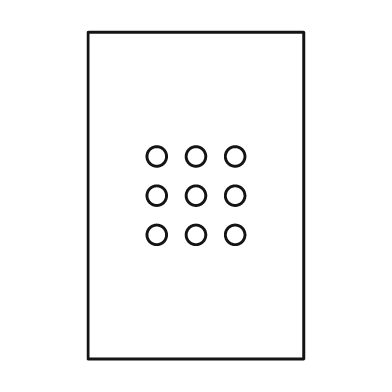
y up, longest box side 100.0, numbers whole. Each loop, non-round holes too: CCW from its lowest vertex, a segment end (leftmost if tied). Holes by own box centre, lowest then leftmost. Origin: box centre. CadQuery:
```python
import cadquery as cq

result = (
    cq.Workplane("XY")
    .moveTo(-33.0, -50.0)
    .lineTo(33.0, -50.0)
    .lineTo(33.0, 50.0)
    .lineTo(-33.0, 50.0)
    .close()
    .moveTo(-12.0, -12.0)
    .circle(3.0)
    .moveTo(0.0, -12.0)
    .circle(3.0)
    .moveTo(12.0, -12.0)
    .circle(3.0)
    .moveTo(-12.0, 0.0)
    .circle(3.0)
    .moveTo(0.0, 0.0)
    .circle(3.0)
    .moveTo(12.0, 0.0)
    .circle(3.0)
    .moveTo(-12.0, 12.0)
    .circle(3.0)
    .moveTo(0.0, 12.0)
    .circle(3.0)
    .moveTo(12.0, 12.0)
    .circle(3.0)
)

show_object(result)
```